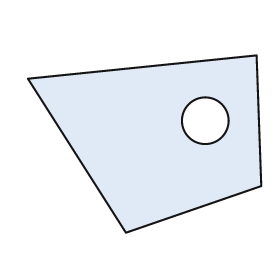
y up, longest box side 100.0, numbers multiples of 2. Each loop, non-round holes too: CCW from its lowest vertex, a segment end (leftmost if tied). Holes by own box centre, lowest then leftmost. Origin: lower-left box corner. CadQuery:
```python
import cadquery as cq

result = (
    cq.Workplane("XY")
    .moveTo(42.0, 0.0)
    .lineTo(100.0, 20.0)
    .lineTo(98.0, 76.0)
    .lineTo(0.0, 66.0)
    .close()
    .moveTo(76.0, 48.0)
    .circle(10.0)
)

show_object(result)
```